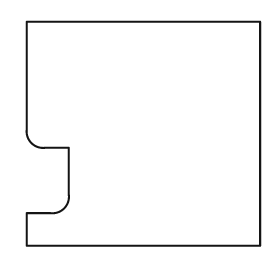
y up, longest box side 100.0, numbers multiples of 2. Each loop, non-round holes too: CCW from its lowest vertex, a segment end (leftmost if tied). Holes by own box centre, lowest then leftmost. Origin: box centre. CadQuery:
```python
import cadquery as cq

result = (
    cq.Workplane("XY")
    .moveTo(-50.0, -48.0)
    .lineTo(50.0, -48.0)
    .lineTo(50.0, 48.0)
    .lineTo(-50.0, 48.0)
    .lineTo(-50.0, 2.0)
    .threePointArc((-48.0, -4.0), (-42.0, -6.0))
    .lineTo(-32.0, -6.0)
    .lineTo(-32.0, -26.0)
    .threePointArc((-34.0, -32.0), (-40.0, -34.0))
    .lineTo(-50.0, -34.0)
    .close()
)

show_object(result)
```